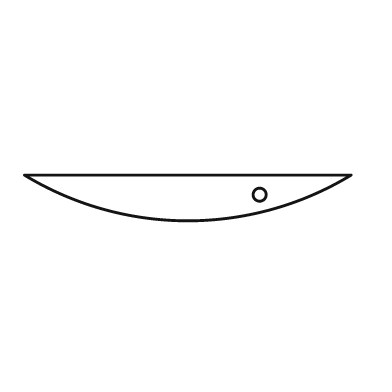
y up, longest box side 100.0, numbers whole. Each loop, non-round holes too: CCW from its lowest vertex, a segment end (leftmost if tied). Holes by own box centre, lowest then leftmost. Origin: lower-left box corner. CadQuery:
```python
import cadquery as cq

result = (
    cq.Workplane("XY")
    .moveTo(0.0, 14.0)
    .threePointArc((50.0, 0.0), (100.0, 14.0))
    .close()
    .moveTo(72.0, 8.0)
    .circle(2.0)
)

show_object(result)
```